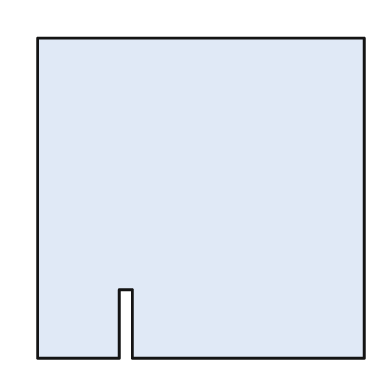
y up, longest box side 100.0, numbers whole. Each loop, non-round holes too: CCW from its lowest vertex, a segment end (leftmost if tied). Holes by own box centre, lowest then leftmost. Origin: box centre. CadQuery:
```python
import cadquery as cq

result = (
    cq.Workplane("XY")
    .moveTo(-50.0, -49.0)
    .lineTo(-25.0, -49.0)
    .lineTo(-25.0, -28.0)
    .lineTo(-21.0, -28.0)
    .lineTo(-21.0, -49.0)
    .lineTo(50.0, -49.0)
    .lineTo(50.0, 49.0)
    .lineTo(-50.0, 49.0)
    .close()
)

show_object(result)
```